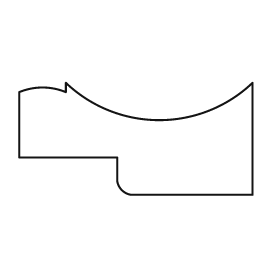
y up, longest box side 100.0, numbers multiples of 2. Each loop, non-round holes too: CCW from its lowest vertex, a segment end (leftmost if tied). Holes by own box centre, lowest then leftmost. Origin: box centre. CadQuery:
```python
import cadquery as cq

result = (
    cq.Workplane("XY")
    .moveTo(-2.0, -24.0)
    .lineTo(50.0, -24.0)
    .lineTo(50.0, 24.0)
    .threePointArc((10.0, 8.0), (-30.0, 24.0))
    .lineTo(-30.0, 20.0)
    .threePointArc((-40.0, 22.0), (-50.0, 20.0))
    .lineTo(-50.0, -8.0)
    .lineTo(-8.0, -8.0)
    .lineTo(-8.0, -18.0)
    .threePointArc((-6.0, -22.0), (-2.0, -24.0))
    .close()
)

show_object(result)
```